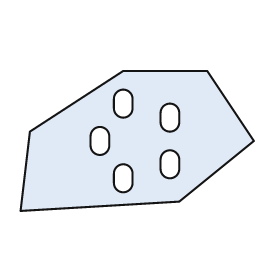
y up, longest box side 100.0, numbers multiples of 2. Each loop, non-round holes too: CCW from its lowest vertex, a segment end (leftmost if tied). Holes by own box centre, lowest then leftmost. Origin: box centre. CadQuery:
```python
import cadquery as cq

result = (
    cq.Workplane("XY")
    .moveTo(-50.0, -30.0)
    .lineTo(18.0, -26.0)
    .lineTo(50.0, 0.0)
    .lineTo(30.0, 30.0)
    .lineTo(-6.0, 30.0)
    .lineTo(-46.0, 4.0)
    .close()
    .moveTo(-10.0, -18.0)
    .threePointArc((-6.0, -22.0), (-2.0, -18.0))
    .lineTo(-2.0, -14.0)
    .threePointArc((-6.0, -10.0), (-10.0, -14.0))
    .close()
    .moveTo(10.0, -12.0)
    .threePointArc((14.0, -16.0), (18.0, -12.0))
    .lineTo(18.0, -8.0)
    .threePointArc((14.0, -4.0), (10.0, -8.0))
    .close()
    .moveTo(-20.0, -2.0)
    .threePointArc((-16.0, -6.0), (-12.0, -2.0))
    .lineTo(-12.0, 2.0)
    .threePointArc((-16.0, 6.0), (-20.0, 2.0))
    .close()
    .moveTo(10.0, 8.0)
    .threePointArc((14.0, 4.0), (18.0, 8.0))
    .lineTo(18.0, 12.0)
    .threePointArc((14.0, 16.0), (10.0, 12.0))
    .close()
    .moveTo(-10.0, 14.0)
    .threePointArc((-6.0, 10.0), (-2.0, 14.0))
    .lineTo(-2.0, 18.0)
    .threePointArc((-6.0, 22.0), (-10.0, 18.0))
    .close()
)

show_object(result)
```